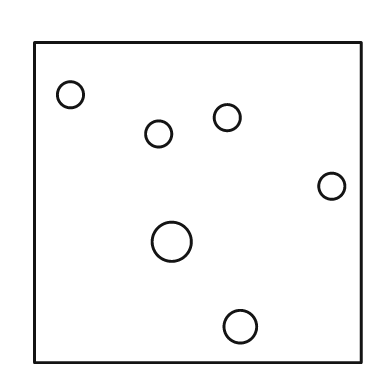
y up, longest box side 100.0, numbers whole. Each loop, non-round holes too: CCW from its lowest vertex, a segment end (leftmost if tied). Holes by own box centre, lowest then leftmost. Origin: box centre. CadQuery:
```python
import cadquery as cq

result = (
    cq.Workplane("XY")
    .moveTo(-50.0, -49.0)
    .lineTo(50.0, -49.0)
    .lineTo(50.0, 49.0)
    .lineTo(-50.0, 49.0)
    .close()
    .moveTo(13.0, -38.0)
    .circle(5.0)
    .moveTo(-8.0, -12.0)
    .circle(6.0)
    .moveTo(41.0, 5.0)
    .circle(4.0)
    .moveTo(-12.0, 21.0)
    .circle(4.0)
    .moveTo(9.0, 26.0)
    .circle(4.0)
    .moveTo(-39.0, 33.0)
    .circle(4.0)
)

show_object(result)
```